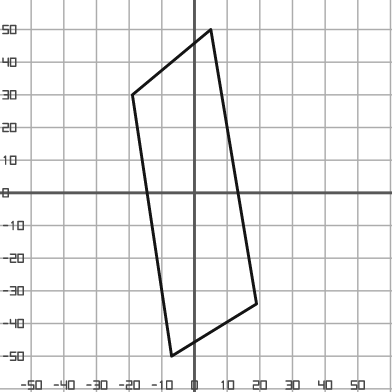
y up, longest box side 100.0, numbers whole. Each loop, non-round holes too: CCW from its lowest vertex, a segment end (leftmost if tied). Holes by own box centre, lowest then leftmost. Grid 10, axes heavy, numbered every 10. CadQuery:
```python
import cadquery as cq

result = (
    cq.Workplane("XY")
    .moveTo(-7.0, -50.0)
    .lineTo(19.0, -34.0)
    .lineTo(5.0, 50.0)
    .lineTo(-19.0, 30.0)
    .close()
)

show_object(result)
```